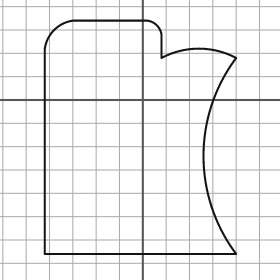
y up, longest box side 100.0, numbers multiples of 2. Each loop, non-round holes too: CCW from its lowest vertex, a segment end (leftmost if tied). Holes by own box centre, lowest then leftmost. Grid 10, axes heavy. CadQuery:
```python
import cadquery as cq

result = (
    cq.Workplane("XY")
    .moveTo(-42.0, -66.0)
    .lineTo(40.0, -66.0)
    .threePointArc((26.0, -24.0), (40.0, 18.0))
    .threePointArc((24.0, 22.0), (8.0, 18.0))
    .lineTo(8.0, 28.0)
    .threePointArc((6.0, 32.0), (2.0, 34.0))
    .lineTo(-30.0, 34.0)
    .threePointArc((-38.0, 30.0), (-42.0, 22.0))
    .close()
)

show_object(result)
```